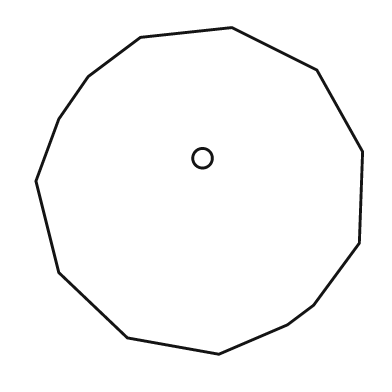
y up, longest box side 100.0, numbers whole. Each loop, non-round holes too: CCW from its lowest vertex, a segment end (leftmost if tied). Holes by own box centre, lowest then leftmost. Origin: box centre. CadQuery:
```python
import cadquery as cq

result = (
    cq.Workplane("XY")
    .moveTo(6.0, -50.0)
    .lineTo(27.0, -41.0)
    .lineTo(35.0, -35.0)
    .lineTo(49.0, -16.0)
    .lineTo(50.0, 12.0)
    .lineTo(36.0, 37.0)
    .lineTo(10.0, 50.0)
    .lineTo(-18.0, 47.0)
    .lineTo(-34.0, 35.0)
    .lineTo(-43.0, 22.0)
    .lineTo(-50.0, 3.0)
    .lineTo(-43.0, -25.0)
    .lineTo(-22.0, -45.0)
    .close()
    .moveTo(1.0, 10.0)
    .circle(3.0)
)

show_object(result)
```